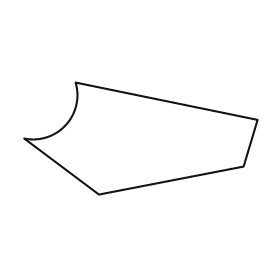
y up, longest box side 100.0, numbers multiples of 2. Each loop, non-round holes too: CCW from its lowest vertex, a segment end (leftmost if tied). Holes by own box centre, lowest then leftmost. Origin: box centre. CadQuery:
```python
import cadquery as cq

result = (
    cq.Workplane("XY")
    .moveTo(-18.0, -24.0)
    .lineTo(44.0, -12.0)
    .lineTo(50.0, 8.0)
    .lineTo(-28.0, 24.0)
    .threePointArc((-32.0, 6.0), (-50.0, 0.0))
    .close()
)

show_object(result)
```